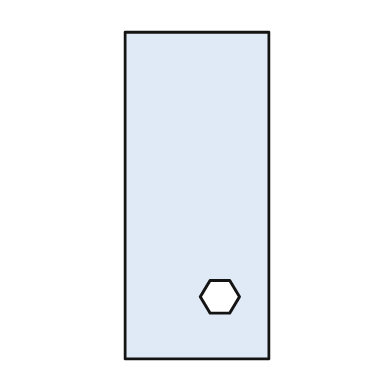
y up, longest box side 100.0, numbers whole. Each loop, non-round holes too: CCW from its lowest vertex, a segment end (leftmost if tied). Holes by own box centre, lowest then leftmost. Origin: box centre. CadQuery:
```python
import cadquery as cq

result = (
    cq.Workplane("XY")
    .moveTo(-22.0, -50.0)
    .lineTo(22.0, -50.0)
    .lineTo(22.0, 50.0)
    .lineTo(-22.0, 50.0)
    .close()
    .moveTo(4.0, -36.0)
    .lineTo(10.0, -36.0)
    .lineTo(13.0, -31.0)
    .lineTo(10.0, -26.0)
    .lineTo(4.0, -26.0)
    .lineTo(1.0, -31.0)
    .close()
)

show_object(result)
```